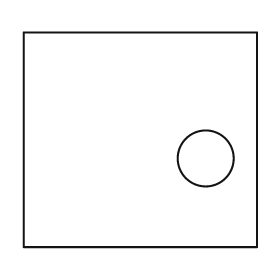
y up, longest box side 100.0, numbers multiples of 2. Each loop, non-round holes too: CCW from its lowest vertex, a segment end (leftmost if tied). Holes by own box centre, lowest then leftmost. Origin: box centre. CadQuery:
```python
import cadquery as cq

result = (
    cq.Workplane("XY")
    .moveTo(-50.0, -46.0)
    .lineTo(50.0, -46.0)
    .lineTo(50.0, 46.0)
    .lineTo(-50.0, 46.0)
    .close()
    .moveTo(28.0, -8.0)
    .circle(12.0)
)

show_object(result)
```